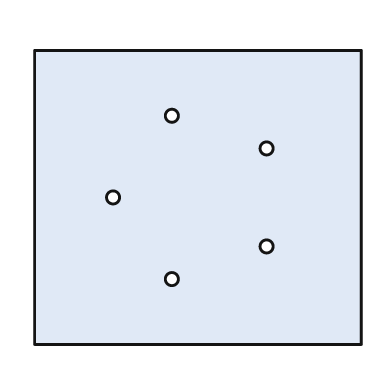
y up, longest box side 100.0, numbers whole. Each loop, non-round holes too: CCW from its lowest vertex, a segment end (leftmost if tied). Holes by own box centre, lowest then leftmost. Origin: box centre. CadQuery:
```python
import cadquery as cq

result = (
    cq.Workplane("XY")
    .moveTo(-50.0, -45.0)
    .lineTo(50.0, -45.0)
    .lineTo(50.0, 45.0)
    .lineTo(-50.0, 45.0)
    .close()
    .moveTo(-8.0, -25.0)
    .circle(2.0)
    .moveTo(21.0, -15.0)
    .circle(2.0)
    .moveTo(-26.0, 0.0)
    .circle(2.0)
    .moveTo(21.0, 15.0)
    .circle(2.0)
    .moveTo(-8.0, 25.0)
    .circle(2.0)
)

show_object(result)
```